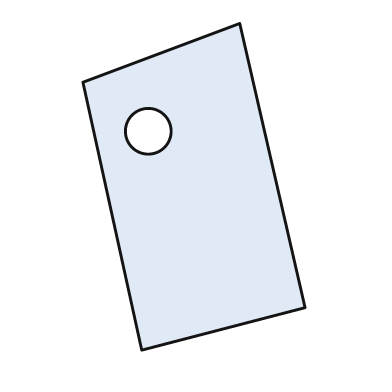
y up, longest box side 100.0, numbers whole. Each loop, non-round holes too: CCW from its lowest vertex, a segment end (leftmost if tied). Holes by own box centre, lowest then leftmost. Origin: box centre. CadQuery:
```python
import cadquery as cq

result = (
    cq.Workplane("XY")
    .moveTo(-16.0, -50.0)
    .lineTo(34.0, -37.0)
    .lineTo(14.0, 50.0)
    .lineTo(-34.0, 32.0)
    .close()
    .moveTo(-14.0, 17.0)
    .circle(7.0)
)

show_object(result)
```